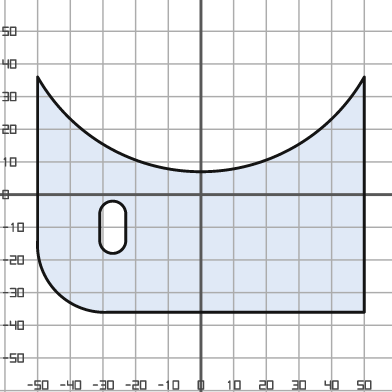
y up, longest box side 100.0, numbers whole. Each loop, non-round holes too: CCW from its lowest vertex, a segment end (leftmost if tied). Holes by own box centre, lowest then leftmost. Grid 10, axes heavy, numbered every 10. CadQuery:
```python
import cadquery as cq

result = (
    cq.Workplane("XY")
    .moveTo(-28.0, -36.0)
    .lineTo(50.0, -36.0)
    .lineTo(50.0, 36.0)
    .threePointArc((0.0, 7.0), (-50.0, 36.0))
    .lineTo(-50.0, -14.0)
    .threePointArc((-44.0, -30.0), (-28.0, -36.0))
    .close()
    .moveTo(-31.0, -14.0)
    .threePointArc((-27.0, -18.0), (-23.0, -14.0))
    .lineTo(-23.0, -6.0)
    .threePointArc((-27.0, -2.0), (-31.0, -6.0))
    .close()
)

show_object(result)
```